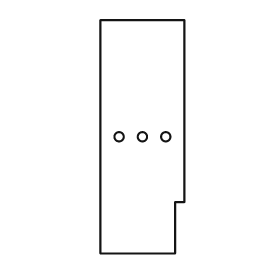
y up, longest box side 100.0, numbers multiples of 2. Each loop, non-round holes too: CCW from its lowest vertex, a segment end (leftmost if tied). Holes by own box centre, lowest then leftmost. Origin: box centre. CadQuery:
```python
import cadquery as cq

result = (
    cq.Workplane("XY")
    .moveTo(-18.0, -50.0)
    .lineTo(14.0, -50.0)
    .lineTo(14.0, -28.0)
    .lineTo(18.0, -28.0)
    .lineTo(18.0, 50.0)
    .lineTo(-18.0, 50.0)
    .close()
    .moveTo(-10.0, 0.0)
    .circle(2.0)
    .moveTo(0.0, 0.0)
    .circle(2.0)
    .moveTo(10.0, 0.0)
    .circle(2.0)
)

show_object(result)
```